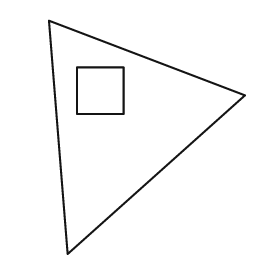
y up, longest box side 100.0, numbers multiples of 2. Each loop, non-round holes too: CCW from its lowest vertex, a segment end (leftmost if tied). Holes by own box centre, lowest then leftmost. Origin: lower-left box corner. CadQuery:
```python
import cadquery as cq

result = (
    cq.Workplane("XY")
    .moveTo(8.0, 0.0)
    .lineTo(84.0, 68.0)
    .lineTo(0.0, 100.0)
    .close()
    .moveTo(12.0, 60.0)
    .lineTo(32.0, 60.0)
    .lineTo(32.0, 80.0)
    .lineTo(12.0, 80.0)
    .close()
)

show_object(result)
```